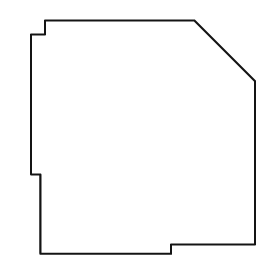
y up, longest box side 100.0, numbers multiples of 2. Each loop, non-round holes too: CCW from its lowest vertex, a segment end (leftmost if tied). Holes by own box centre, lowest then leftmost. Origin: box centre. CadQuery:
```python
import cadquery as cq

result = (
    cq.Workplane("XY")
    .moveTo(-44.0, -50.0)
    .lineTo(12.0, -50.0)
    .lineTo(12.0, -46.0)
    .lineTo(48.0, -46.0)
    .lineTo(48.0, 24.0)
    .lineTo(22.0, 50.0)
    .lineTo(-42.0, 50.0)
    .lineTo(-42.0, 44.0)
    .lineTo(-48.0, 44.0)
    .lineTo(-48.0, -16.0)
    .lineTo(-44.0, -16.0)
    .close()
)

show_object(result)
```